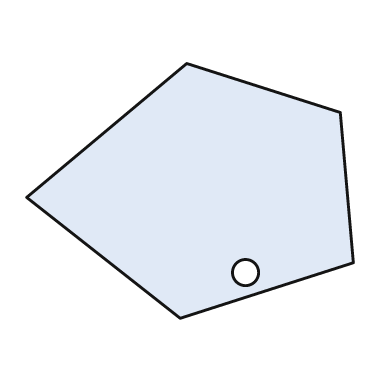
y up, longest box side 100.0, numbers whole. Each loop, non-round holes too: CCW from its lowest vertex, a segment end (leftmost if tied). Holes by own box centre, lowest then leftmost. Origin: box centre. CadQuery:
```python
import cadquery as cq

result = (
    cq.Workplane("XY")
    .moveTo(-3.0, -39.0)
    .lineTo(50.0, -22.0)
    .lineTo(46.0, 24.0)
    .lineTo(-1.0, 39.0)
    .lineTo(-50.0, -2.0)
    .close()
    .moveTo(17.0, -25.0)
    .circle(4.0)
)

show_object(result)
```